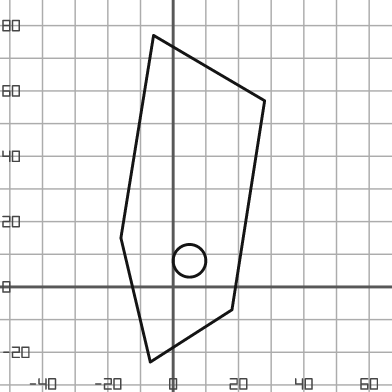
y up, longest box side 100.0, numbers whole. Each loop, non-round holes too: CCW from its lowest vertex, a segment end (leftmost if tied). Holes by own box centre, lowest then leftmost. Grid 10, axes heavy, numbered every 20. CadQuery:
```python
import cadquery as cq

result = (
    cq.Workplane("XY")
    .moveTo(-7.0, -23.0)
    .lineTo(18.0, -7.0)
    .lineTo(28.0, 57.0)
    .lineTo(-6.0, 77.0)
    .lineTo(-16.0, 15.0)
    .close()
    .moveTo(5.0, 8.0)
    .circle(5.0)
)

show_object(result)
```